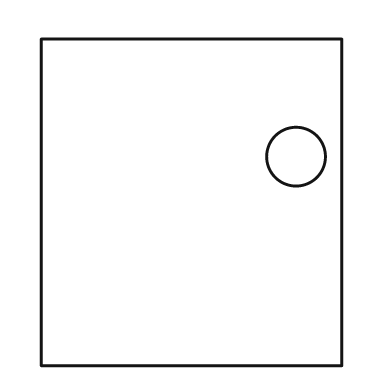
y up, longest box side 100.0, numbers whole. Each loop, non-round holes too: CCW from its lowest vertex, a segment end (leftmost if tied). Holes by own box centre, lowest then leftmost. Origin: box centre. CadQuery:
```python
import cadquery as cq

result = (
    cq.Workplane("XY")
    .moveTo(-46.0, -50.0)
    .lineTo(46.0, -50.0)
    .lineTo(46.0, 50.0)
    .lineTo(-46.0, 50.0)
    .close()
    .moveTo(32.0, 14.0)
    .circle(9.0)
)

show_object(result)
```